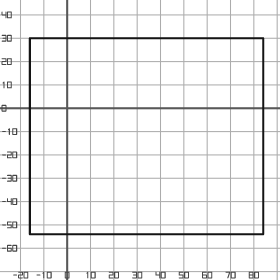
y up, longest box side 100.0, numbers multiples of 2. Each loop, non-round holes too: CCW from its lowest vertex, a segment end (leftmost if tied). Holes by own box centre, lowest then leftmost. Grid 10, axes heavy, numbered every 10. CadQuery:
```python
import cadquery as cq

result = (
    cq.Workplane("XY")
    .moveTo(-16.0, -54.0)
    .lineTo(84.0, -54.0)
    .lineTo(84.0, 30.0)
    .lineTo(-16.0, 30.0)
    .close()
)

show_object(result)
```